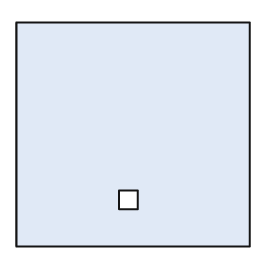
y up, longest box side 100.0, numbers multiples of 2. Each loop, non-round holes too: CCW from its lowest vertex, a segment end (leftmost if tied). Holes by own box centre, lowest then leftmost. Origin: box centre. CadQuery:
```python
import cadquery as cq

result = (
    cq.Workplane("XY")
    .moveTo(-50.0, -48.0)
    .lineTo(50.0, -48.0)
    .lineTo(50.0, 48.0)
    .lineTo(-50.0, 48.0)
    .close()
    .moveTo(-6.0, -32.0)
    .lineTo(2.0, -32.0)
    .lineTo(2.0, -24.0)
    .lineTo(-6.0, -24.0)
    .close()
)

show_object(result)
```